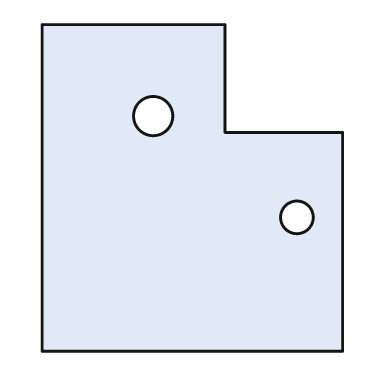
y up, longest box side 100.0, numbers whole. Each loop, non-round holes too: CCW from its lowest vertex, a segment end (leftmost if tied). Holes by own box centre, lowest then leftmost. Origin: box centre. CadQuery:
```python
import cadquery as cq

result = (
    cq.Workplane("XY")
    .moveTo(-46.0, -50.0)
    .lineTo(46.0, -50.0)
    .lineTo(46.0, 17.0)
    .lineTo(10.0, 17.0)
    .lineTo(10.0, 50.0)
    .lineTo(-46.0, 50.0)
    .close()
    .moveTo(32.0, -9.0)
    .circle(5.0)
    .moveTo(-12.0, 22.0)
    .circle(6.0)
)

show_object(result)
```